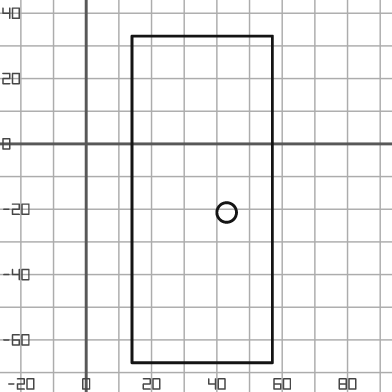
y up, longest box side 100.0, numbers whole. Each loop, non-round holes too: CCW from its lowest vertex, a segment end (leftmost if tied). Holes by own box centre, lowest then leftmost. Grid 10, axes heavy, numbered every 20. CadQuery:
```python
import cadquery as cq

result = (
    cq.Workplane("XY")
    .moveTo(14.0, -67.0)
    .lineTo(57.0, -67.0)
    .lineTo(57.0, 33.0)
    .lineTo(14.0, 33.0)
    .close()
    .moveTo(43.0, -21.0)
    .circle(3.0)
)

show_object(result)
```